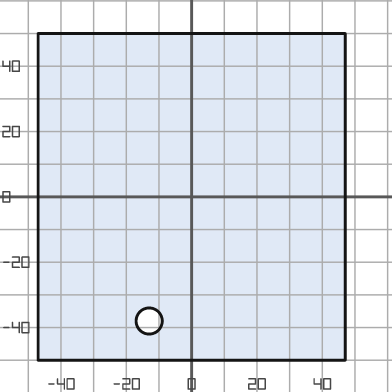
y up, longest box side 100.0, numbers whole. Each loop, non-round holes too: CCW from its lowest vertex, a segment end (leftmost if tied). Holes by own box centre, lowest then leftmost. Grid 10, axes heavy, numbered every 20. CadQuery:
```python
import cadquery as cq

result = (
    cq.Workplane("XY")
    .moveTo(-47.0, -50.0)
    .lineTo(47.0, -50.0)
    .lineTo(47.0, 50.0)
    .lineTo(-47.0, 50.0)
    .close()
    .moveTo(-13.0, -38.0)
    .circle(4.0)
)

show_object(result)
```